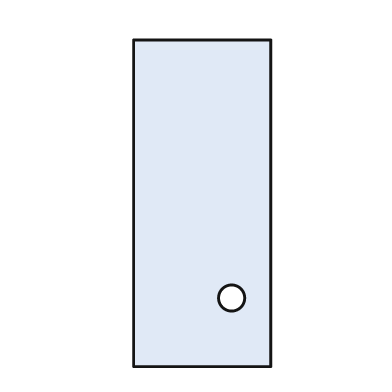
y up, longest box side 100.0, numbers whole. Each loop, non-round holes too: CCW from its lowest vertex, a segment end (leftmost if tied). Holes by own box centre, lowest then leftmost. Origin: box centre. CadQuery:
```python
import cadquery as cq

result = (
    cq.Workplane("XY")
    .moveTo(-21.0, -50.0)
    .lineTo(21.0, -50.0)
    .lineTo(21.0, 50.0)
    .lineTo(-21.0, 50.0)
    .close()
    .moveTo(9.0, -29.0)
    .circle(4.0)
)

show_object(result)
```